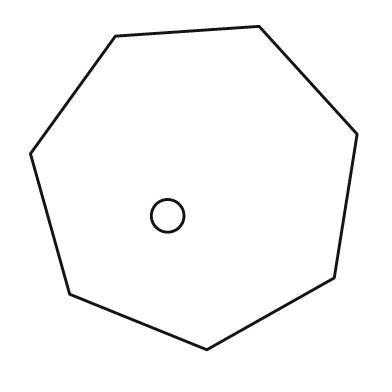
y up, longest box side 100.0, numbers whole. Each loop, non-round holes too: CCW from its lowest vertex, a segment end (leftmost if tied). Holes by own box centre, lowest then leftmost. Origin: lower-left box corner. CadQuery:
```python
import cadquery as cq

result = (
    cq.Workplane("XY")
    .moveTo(54.0, 0.0)
    .lineTo(93.0, 22.0)
    .lineTo(100.0, 66.0)
    .lineTo(70.0, 99.0)
    .lineTo(26.0, 96.0)
    .lineTo(0.0, 60.0)
    .lineTo(12.0, 17.0)
    .close()
    .moveTo(42.0, 41.0)
    .circle(5.0)
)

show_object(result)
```